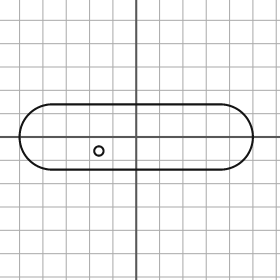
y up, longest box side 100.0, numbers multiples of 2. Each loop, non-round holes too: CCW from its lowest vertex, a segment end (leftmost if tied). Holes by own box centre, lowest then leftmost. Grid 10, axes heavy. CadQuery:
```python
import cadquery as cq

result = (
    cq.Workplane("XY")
    .moveTo(-36.0, -14.0)
    .lineTo(36.0, -14.0)
    .threePointArc((50.0, 0.0), (36.0, 14.0))
    .lineTo(-36.0, 14.0)
    .threePointArc((-50.0, 0.0), (-36.0, -14.0))
    .close()
    .moveTo(-16.0, -6.0)
    .circle(2.0)
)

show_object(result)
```